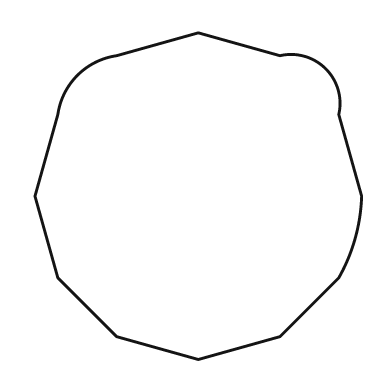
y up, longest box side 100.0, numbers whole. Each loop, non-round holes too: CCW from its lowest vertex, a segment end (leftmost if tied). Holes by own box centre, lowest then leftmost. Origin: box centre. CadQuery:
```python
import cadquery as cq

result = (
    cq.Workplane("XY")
    .moveTo(0.0, -50.0)
    .lineTo(25.0, -43.0)
    .lineTo(43.0, -25.0)
    .threePointArc((48.0, -13.0), (50.0, 0.0))
    .lineTo(43.0, 25.0)
    .threePointArc((39.0, 39.0), (25.0, 43.0))
    .lineTo(0.0, 50.0)
    .lineTo(-25.0, 43.0)
    .threePointArc((-37.0, 37.0), (-43.0, 25.0))
    .lineTo(-50.0, 0.0)
    .lineTo(-43.0, -25.0)
    .lineTo(-25.0, -43.0)
    .close()
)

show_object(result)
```